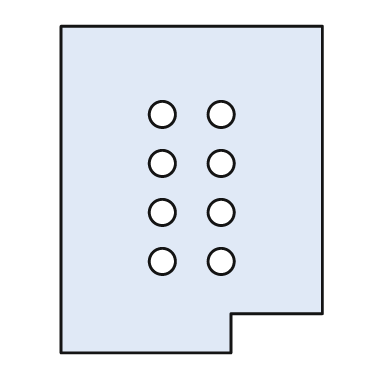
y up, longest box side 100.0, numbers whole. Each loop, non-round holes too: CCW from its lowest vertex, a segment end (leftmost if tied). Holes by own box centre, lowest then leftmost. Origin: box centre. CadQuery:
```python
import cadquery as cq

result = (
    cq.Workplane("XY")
    .moveTo(-40.0, -50.0)
    .lineTo(12.0, -50.0)
    .lineTo(12.0, -38.0)
    .lineTo(40.0, -38.0)
    .lineTo(40.0, 50.0)
    .lineTo(-40.0, 50.0)
    .close()
    .moveTo(-9.0, -22.0)
    .circle(4.0)
    .moveTo(9.0, -22.0)
    .circle(4.0)
    .moveTo(-9.0, -7.0)
    .circle(4.0)
    .moveTo(9.0, -7.0)
    .circle(4.0)
    .moveTo(-9.0, 8.0)
    .circle(4.0)
    .moveTo(9.0, 8.0)
    .circle(4.0)
    .moveTo(-9.0, 23.0)
    .circle(4.0)
    .moveTo(9.0, 23.0)
    .circle(4.0)
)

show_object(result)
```